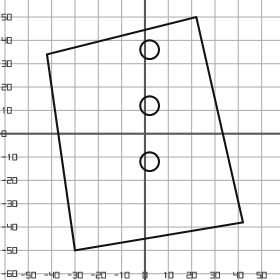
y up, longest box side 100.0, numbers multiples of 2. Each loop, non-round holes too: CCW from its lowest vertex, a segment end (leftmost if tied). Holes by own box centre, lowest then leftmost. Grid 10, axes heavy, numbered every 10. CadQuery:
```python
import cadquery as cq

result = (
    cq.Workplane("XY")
    .moveTo(-30.0, -50.0)
    .lineTo(42.0, -38.0)
    .lineTo(22.0, 50.0)
    .lineTo(-42.0, 34.0)
    .close()
    .moveTo(2.0, -12.0)
    .circle(4.0)
    .moveTo(2.0, 12.0)
    .circle(4.0)
    .moveTo(2.0, 36.0)
    .circle(4.0)
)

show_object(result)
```